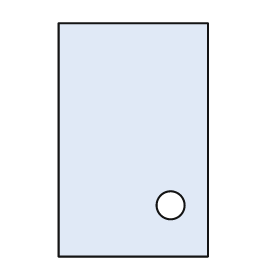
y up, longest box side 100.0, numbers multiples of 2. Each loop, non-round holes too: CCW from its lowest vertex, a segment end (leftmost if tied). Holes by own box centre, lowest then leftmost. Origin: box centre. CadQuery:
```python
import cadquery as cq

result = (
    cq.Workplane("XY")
    .moveTo(-32.0, -50.0)
    .lineTo(32.0, -50.0)
    .lineTo(32.0, 50.0)
    .lineTo(-32.0, 50.0)
    .close()
    .moveTo(16.0, -28.0)
    .circle(6.0)
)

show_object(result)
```